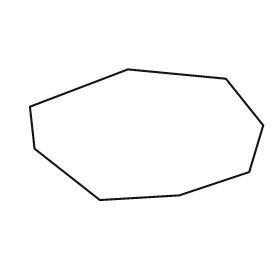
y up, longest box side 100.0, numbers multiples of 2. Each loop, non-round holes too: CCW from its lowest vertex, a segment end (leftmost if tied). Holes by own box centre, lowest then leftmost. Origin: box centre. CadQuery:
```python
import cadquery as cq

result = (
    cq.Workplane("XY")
    .moveTo(-20.0, -28.0)
    .lineTo(14.0, -26.0)
    .lineTo(44.0, -16.0)
    .lineTo(50.0, 4.0)
    .lineTo(34.0, 24.0)
    .lineTo(-8.0, 28.0)
    .lineTo(-50.0, 12.0)
    .lineTo(-48.0, -6.0)
    .close()
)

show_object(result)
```